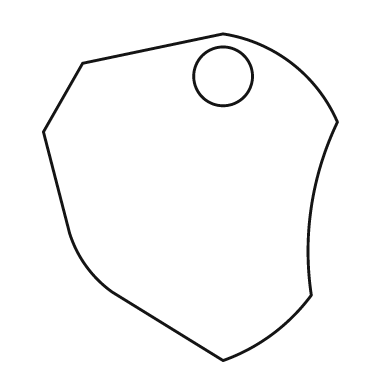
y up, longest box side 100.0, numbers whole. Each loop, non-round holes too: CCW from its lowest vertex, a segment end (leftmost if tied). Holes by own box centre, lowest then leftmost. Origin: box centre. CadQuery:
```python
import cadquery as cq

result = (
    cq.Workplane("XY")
    .moveTo(10.0, -50.0)
    .threePointArc((25.0, -42.0), (37.0, -30.0))
    .threePointArc((37.0, -3.0), (45.0, 23.0))
    .threePointArc((31.0, 41.0), (10.0, 50.0))
    .lineTo(-33.0, 41.0)
    .lineTo(-45.0, 20.0)
    .lineTo(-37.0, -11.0)
    .threePointArc((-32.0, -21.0), (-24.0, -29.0))
    .close()
    .moveTo(10.0, 37.0)
    .circle(9.0)
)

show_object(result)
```